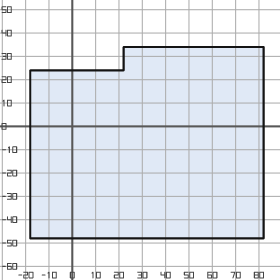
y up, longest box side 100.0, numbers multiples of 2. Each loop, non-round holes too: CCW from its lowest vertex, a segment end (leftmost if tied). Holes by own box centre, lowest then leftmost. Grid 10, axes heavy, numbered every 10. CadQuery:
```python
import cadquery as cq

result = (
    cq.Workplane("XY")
    .moveTo(-18.0, -48.0)
    .lineTo(82.0, -48.0)
    .lineTo(82.0, 34.0)
    .lineTo(22.0, 34.0)
    .lineTo(22.0, 24.0)
    .lineTo(-18.0, 24.0)
    .close()
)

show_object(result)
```